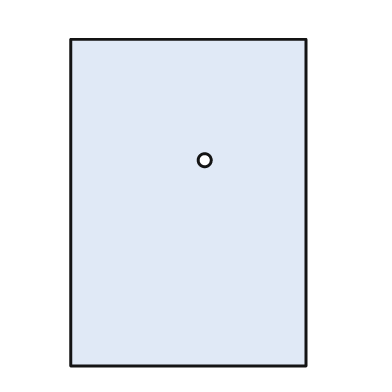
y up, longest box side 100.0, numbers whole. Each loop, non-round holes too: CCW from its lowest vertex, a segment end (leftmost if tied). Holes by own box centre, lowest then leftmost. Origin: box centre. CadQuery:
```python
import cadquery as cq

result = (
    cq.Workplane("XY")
    .moveTo(-36.0, -50.0)
    .lineTo(36.0, -50.0)
    .lineTo(36.0, 50.0)
    .lineTo(-36.0, 50.0)
    .close()
    .moveTo(5.0, 13.0)
    .circle(2.0)
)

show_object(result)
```